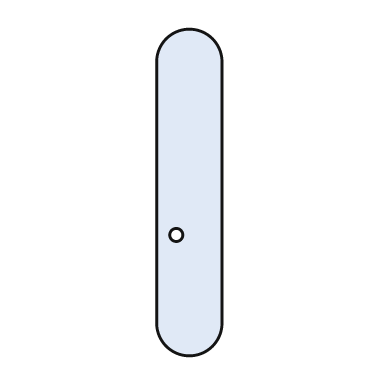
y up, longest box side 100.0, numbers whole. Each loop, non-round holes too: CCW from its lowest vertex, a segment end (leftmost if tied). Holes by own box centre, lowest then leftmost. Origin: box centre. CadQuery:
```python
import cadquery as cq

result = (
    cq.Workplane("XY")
    .moveTo(-10.0, -40.0)
    .threePointArc((0.0, -50.0), (10.0, -40.0))
    .lineTo(10.0, 40.0)
    .threePointArc((0.0, 50.0), (-10.0, 40.0))
    .close()
    .moveTo(-4.0, -13.0)
    .circle(2.0)
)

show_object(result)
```